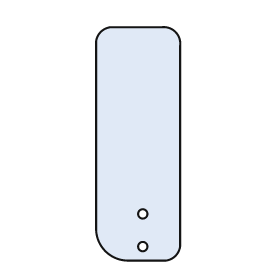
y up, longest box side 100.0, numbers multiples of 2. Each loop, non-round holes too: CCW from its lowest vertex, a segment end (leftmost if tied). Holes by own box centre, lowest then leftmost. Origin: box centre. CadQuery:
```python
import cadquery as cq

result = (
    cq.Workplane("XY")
    .moveTo(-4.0, -50.0)
    .lineTo(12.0, -50.0)
    .threePointArc((16.0, -48.0), (18.0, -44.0))
    .lineTo(18.0, 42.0)
    .threePointArc((16.0, 48.0), (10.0, 50.0))
    .lineTo(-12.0, 50.0)
    .threePointArc((-16.0, 48.0), (-18.0, 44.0))
    .lineTo(-18.0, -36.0)
    .threePointArc((-14.0, -46.0), (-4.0, -50.0))
    .close()
    .moveTo(2.0, -44.0)
    .circle(2.0)
    .moveTo(2.0, -30.0)
    .circle(2.0)
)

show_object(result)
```